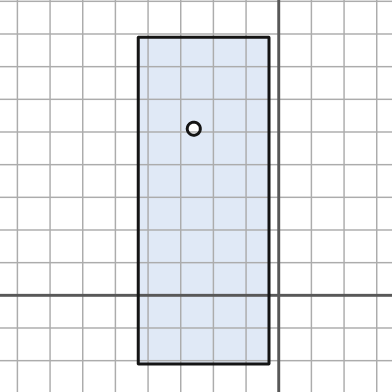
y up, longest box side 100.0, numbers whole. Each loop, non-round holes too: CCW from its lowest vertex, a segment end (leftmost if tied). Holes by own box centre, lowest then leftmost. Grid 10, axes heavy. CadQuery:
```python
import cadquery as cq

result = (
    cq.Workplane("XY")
    .moveTo(-43.0, -21.0)
    .lineTo(-3.0, -21.0)
    .lineTo(-3.0, 79.0)
    .lineTo(-43.0, 79.0)
    .close()
    .moveTo(-26.0, 51.0)
    .circle(2.0)
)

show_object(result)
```